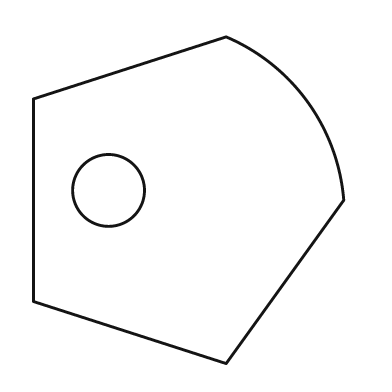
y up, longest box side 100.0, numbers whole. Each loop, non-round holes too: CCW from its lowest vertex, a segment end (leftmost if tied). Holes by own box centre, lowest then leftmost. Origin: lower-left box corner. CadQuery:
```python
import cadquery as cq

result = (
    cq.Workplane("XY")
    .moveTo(59.0, 0.0)
    .lineTo(95.0, 50.0)
    .threePointArc((84.0, 80.0), (59.0, 100.0))
    .lineTo(0.0, 81.0)
    .lineTo(0.0, 19.0)
    .close()
    .moveTo(23.0, 53.0)
    .circle(11.0)
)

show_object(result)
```